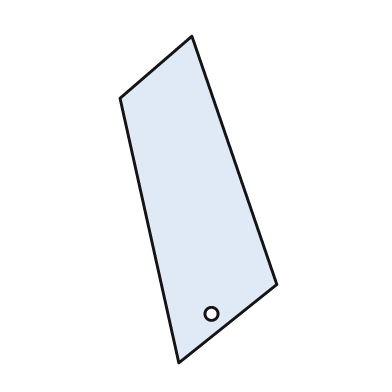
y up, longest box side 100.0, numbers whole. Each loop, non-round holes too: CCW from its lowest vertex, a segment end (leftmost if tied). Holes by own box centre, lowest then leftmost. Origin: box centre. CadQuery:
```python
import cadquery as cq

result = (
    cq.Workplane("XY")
    .moveTo(-6.0, -50.0)
    .lineTo(24.0, -26.0)
    .lineTo(-2.0, 50.0)
    .lineTo(-24.0, 31.0)
    .close()
    .moveTo(4.0, -35.0)
    .circle(2.0)
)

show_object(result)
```